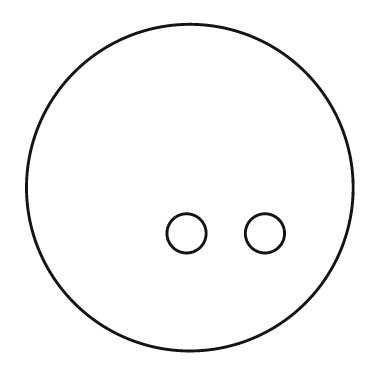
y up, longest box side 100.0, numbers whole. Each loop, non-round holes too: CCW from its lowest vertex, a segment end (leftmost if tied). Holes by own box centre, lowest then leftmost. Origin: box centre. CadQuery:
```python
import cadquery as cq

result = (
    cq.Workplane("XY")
    .moveTo(0.0, 0.0)
    .circle(50.0)
    .moveTo(-1.0, -14.0)
    .circle(6.0)
    .moveTo(23.0, -14.0)
    .circle(6.0)
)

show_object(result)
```